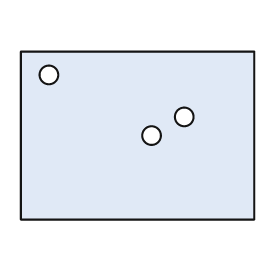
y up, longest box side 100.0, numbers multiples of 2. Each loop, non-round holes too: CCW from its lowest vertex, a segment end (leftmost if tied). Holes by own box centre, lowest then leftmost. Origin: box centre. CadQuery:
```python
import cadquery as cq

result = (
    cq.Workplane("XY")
    .moveTo(-50.0, -36.0)
    .lineTo(50.0, -36.0)
    .lineTo(50.0, 36.0)
    .lineTo(-50.0, 36.0)
    .close()
    .moveTo(6.0, 0.0)
    .circle(4.0)
    .moveTo(20.0, 8.0)
    .circle(4.0)
    .moveTo(-38.0, 26.0)
    .circle(4.0)
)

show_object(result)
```